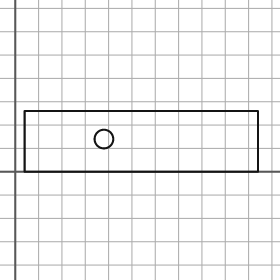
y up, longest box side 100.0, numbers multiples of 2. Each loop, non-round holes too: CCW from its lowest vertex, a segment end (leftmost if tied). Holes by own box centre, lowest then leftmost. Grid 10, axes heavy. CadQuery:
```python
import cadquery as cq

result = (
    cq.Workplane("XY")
    .moveTo(4.0, 0.0)
    .lineTo(104.0, 0.0)
    .lineTo(104.0, 26.0)
    .lineTo(4.0, 26.0)
    .close()
    .moveTo(38.0, 14.0)
    .circle(4.0)
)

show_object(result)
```